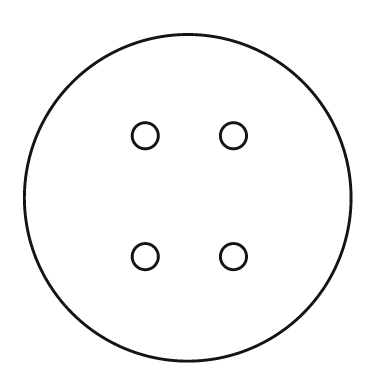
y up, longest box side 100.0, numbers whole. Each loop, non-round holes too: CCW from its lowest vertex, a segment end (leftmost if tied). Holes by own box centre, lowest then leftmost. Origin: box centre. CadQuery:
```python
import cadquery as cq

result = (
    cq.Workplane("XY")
    .moveTo(0.0, 0.0)
    .circle(50.0)
    .moveTo(-13.0, -18.0)
    .circle(4.0)
    .moveTo(14.0, -18.0)
    .circle(4.0)
    .moveTo(-13.0, 19.0)
    .circle(4.0)
    .moveTo(14.0, 19.0)
    .circle(4.0)
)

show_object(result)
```